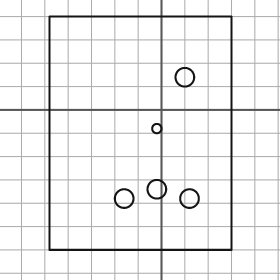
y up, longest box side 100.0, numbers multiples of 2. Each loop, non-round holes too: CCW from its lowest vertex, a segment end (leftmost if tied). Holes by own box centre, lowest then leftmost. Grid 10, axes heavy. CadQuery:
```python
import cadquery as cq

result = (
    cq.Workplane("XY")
    .moveTo(-48.0, -60.0)
    .lineTo(30.0, -60.0)
    .lineTo(30.0, 40.0)
    .lineTo(-48.0, 40.0)
    .close()
    .moveTo(-16.0, -38.0)
    .circle(4.0)
    .moveTo(12.0, -38.0)
    .circle(4.0)
    .moveTo(-2.0, -34.0)
    .circle(4.0)
    .moveTo(-2.0, -8.0)
    .circle(2.0)
    .moveTo(10.0, 14.0)
    .circle(4.0)
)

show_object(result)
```